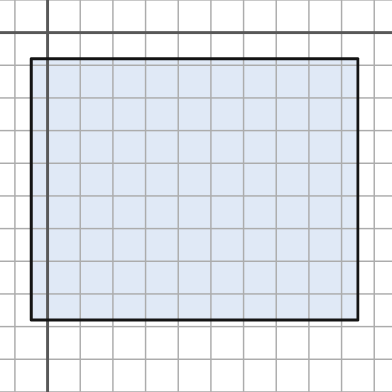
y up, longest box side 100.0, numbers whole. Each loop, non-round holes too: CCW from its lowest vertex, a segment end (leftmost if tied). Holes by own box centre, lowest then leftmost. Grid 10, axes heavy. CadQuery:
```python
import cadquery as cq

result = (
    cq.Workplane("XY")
    .moveTo(-5.0, -88.0)
    .lineTo(95.0, -88.0)
    .lineTo(95.0, -8.0)
    .lineTo(-5.0, -8.0)
    .close()
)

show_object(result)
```